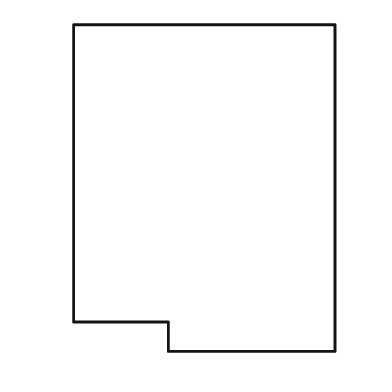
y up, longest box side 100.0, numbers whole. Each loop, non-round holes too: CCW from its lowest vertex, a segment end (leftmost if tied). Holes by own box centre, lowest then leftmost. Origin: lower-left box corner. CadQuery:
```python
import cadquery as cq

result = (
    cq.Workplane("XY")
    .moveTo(29.0, 0.0)
    .lineTo(80.0, 0.0)
    .lineTo(80.0, 100.0)
    .lineTo(0.0, 100.0)
    .lineTo(0.0, 9.0)
    .lineTo(29.0, 9.0)
    .close()
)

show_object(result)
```